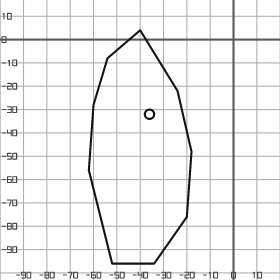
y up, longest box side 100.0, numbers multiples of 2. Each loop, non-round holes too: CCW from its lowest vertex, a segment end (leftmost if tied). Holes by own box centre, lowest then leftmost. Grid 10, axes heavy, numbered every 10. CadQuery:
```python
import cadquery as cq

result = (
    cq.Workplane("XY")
    .moveTo(-52.0, -96.0)
    .lineTo(-34.0, -96.0)
    .lineTo(-20.0, -76.0)
    .lineTo(-18.0, -48.0)
    .lineTo(-24.0, -22.0)
    .lineTo(-40.0, 4.0)
    .lineTo(-54.0, -8.0)
    .lineTo(-60.0, -28.0)
    .lineTo(-62.0, -56.0)
    .close()
    .moveTo(-36.0, -32.0)
    .circle(2.0)
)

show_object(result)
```